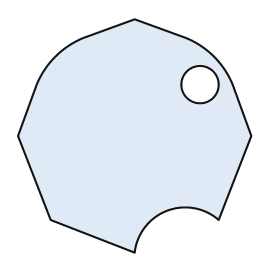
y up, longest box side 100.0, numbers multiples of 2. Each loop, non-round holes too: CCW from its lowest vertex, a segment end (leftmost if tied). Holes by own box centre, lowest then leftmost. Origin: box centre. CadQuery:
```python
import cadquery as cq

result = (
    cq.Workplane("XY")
    .moveTo(0.0, -50.0)
    .threePointArc((14.0, -32.0), (36.0, -36.0))
    .lineTo(50.0, 0.0)
    .lineTo(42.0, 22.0)
    .threePointArc((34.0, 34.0), (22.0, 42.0))
    .lineTo(0.0, 50.0)
    .lineTo(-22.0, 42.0)
    .threePointArc((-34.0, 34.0), (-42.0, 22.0))
    .lineTo(-50.0, 0.0)
    .lineTo(-36.0, -36.0)
    .close()
    .moveTo(28.0, 22.0)
    .circle(8.0)
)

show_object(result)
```